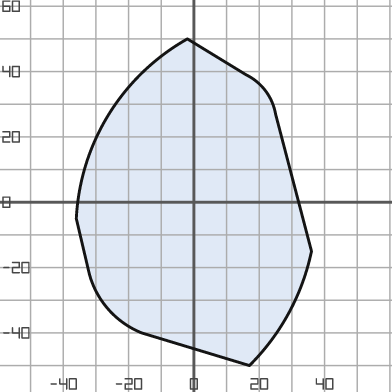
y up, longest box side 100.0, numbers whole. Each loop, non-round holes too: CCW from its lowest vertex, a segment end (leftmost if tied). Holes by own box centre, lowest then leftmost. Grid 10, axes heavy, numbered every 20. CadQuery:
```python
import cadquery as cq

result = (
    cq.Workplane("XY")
    .moveTo(17.0, -50.0)
    .threePointArc((29.0, -34.0), (36.0, -15.0))
    .lineTo(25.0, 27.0)
    .threePointArc((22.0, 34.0), (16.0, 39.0))
    .lineTo(-2.0, 50.0)
    .threePointArc((-26.0, 27.0), (-36.0, -5.0))
    .lineTo(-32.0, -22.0)
    .threePointArc((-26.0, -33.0), (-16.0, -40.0))
    .close()
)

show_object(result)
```